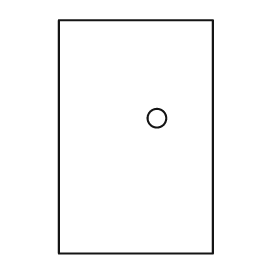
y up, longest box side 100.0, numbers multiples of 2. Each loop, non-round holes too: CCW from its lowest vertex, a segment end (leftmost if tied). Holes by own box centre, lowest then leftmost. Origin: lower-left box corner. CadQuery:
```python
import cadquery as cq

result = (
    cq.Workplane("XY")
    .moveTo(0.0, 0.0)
    .lineTo(66.0, 0.0)
    .lineTo(66.0, 100.0)
    .lineTo(0.0, 100.0)
    .close()
    .moveTo(42.0, 58.0)
    .circle(4.0)
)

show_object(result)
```